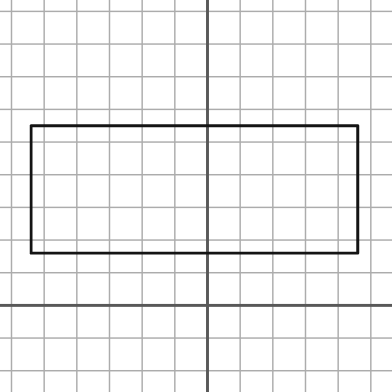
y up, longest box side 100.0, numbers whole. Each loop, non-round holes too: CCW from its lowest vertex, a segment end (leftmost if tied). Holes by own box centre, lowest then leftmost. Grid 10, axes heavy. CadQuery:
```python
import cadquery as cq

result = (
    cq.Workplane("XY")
    .moveTo(-54.0, 16.0)
    .lineTo(46.0, 16.0)
    .lineTo(46.0, 55.0)
    .lineTo(-54.0, 55.0)
    .close()
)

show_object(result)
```